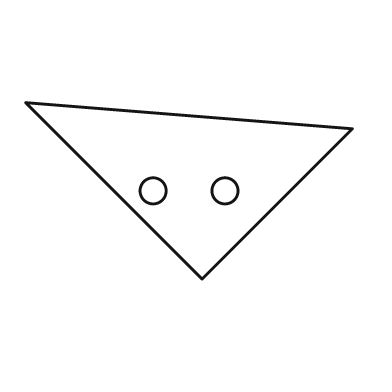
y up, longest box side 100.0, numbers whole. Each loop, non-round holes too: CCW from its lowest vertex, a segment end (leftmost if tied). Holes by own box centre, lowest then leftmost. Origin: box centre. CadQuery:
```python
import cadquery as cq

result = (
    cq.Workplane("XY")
    .moveTo(4.0, -27.0)
    .lineTo(50.0, 19.0)
    .lineTo(-50.0, 27.0)
    .close()
    .moveTo(-11.0, 0.0)
    .circle(4.0)
    .moveTo(11.0, 0.0)
    .circle(4.0)
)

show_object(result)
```